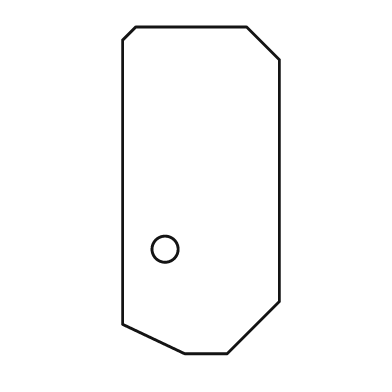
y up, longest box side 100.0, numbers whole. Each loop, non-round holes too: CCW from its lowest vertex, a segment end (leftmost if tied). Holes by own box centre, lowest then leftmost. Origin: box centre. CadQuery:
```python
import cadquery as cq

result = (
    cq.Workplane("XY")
    .moveTo(-5.0, -50.0)
    .lineTo(8.0, -50.0)
    .lineTo(24.0, -34.0)
    .lineTo(24.0, 40.0)
    .lineTo(14.0, 50.0)
    .lineTo(-20.0, 50.0)
    .lineTo(-24.0, 46.0)
    .lineTo(-24.0, -41.0)
    .close()
    .moveTo(-11.0, -18.0)
    .circle(4.0)
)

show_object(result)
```